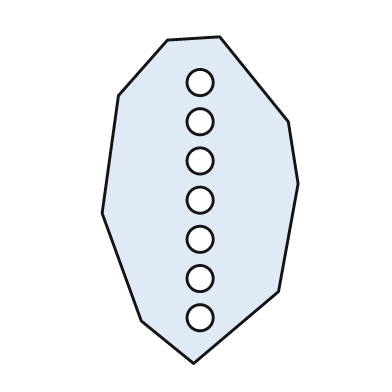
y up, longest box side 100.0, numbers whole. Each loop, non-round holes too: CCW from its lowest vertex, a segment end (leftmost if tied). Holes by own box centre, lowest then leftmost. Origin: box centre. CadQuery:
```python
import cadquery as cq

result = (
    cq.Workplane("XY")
    .moveTo(-2.0, -50.0)
    .lineTo(24.0, -28.0)
    .lineTo(30.0, 5.0)
    .lineTo(27.0, 24.0)
    .lineTo(6.0, 50.0)
    .lineTo(-10.0, 49.0)
    .lineTo(-25.0, 32.0)
    .lineTo(-30.0, -4.0)
    .lineTo(-18.0, -37.0)
    .close()
    .moveTo(0.0, -36.0)
    .circle(4.0)
    .moveTo(0.0, -24.0)
    .circle(4.0)
    .moveTo(0.0, -12.0)
    .circle(4.0)
    .moveTo(0.0, 0.0)
    .circle(4.0)
    .moveTo(0.0, 12.0)
    .circle(4.0)
    .moveTo(0.0, 24.0)
    .circle(4.0)
    .moveTo(0.0, 36.0)
    .circle(4.0)
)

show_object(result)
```